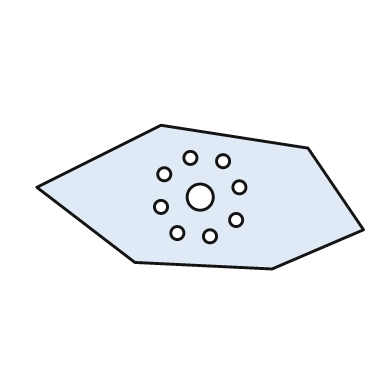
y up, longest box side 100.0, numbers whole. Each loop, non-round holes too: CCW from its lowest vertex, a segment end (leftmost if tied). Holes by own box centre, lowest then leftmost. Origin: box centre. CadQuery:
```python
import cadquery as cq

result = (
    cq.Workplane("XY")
    .moveTo(22.0, -22.0)
    .lineTo(50.0, -10.0)
    .lineTo(33.0, 15.0)
    .lineTo(-12.0, 22.0)
    .lineTo(-50.0, 3.0)
    .lineTo(-20.0, -20.0)
    .close()
    .moveTo(3.0, -12.0)
    .circle(2.0)
    .moveTo(-7.0, -11.0)
    .circle(2.0)
    .moveTo(11.0, -7.0)
    .circle(2.0)
    .moveTo(-12.0, -3.0)
    .circle(2.0)
    .moveTo(0.0, 0.0)
    .circle(4.0)
    .moveTo(12.0, 3.0)
    .circle(2.0)
    .moveTo(-11.0, 7.0)
    .circle(2.0)
    .moveTo(7.0, 11.0)
    .circle(2.0)
    .moveTo(-3.0, 12.0)
    .circle(2.0)
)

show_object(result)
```